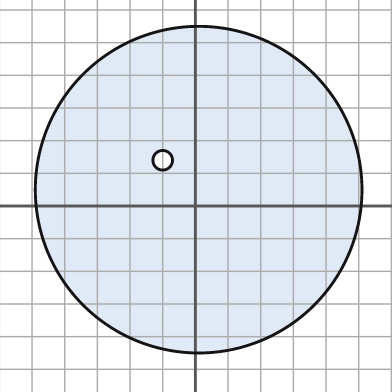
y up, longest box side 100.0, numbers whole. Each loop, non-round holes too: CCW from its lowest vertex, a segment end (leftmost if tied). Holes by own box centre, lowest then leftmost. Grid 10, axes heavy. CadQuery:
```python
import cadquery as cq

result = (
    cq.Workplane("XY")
    .moveTo(1.0, 5.0)
    .circle(50.0)
    .moveTo(-10.0, 14.0)
    .circle(3.0)
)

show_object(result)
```